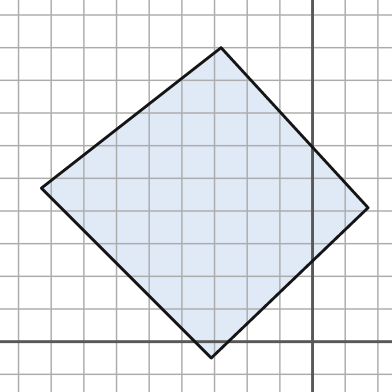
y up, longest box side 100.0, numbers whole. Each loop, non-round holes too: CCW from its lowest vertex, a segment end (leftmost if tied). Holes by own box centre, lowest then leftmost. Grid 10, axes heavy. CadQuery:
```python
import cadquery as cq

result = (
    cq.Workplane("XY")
    .moveTo(-31.0, -5.0)
    .lineTo(17.0, 41.0)
    .lineTo(-28.0, 90.0)
    .lineTo(-83.0, 47.0)
    .close()
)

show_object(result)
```